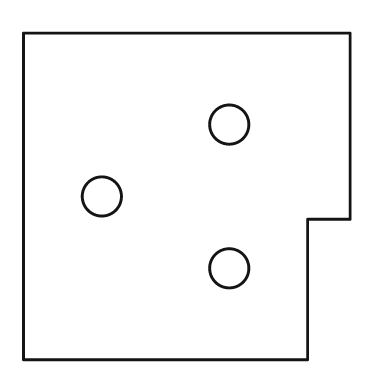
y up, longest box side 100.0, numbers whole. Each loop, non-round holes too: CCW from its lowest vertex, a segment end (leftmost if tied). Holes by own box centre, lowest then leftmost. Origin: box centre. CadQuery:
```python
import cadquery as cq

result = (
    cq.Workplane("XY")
    .moveTo(-50.0, -50.0)
    .lineTo(37.0, -50.0)
    .lineTo(37.0, -7.0)
    .lineTo(50.0, -7.0)
    .lineTo(50.0, 50.0)
    .lineTo(-50.0, 50.0)
    .close()
    .moveTo(13.0, -22.0)
    .circle(6.0)
    .moveTo(-26.0, 0.0)
    .circle(6.0)
    .moveTo(13.0, 22.0)
    .circle(6.0)
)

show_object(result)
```